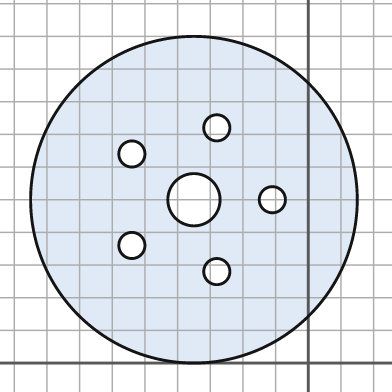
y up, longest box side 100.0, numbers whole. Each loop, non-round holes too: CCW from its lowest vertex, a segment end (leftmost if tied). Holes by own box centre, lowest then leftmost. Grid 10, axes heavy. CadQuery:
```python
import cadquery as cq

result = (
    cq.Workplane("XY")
    .moveTo(-35.0, 50.0)
    .circle(50.0)
    .moveTo(-28.0, 28.0)
    .circle(4.0)
    .moveTo(-54.0, 36.0)
    .circle(4.0)
    .moveTo(-35.0, 50.0)
    .circle(8.0)
    .moveTo(-11.0, 50.0)
    .circle(4.0)
    .moveTo(-54.0, 64.0)
    .circle(4.0)
    .moveTo(-28.0, 72.0)
    .circle(4.0)
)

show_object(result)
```